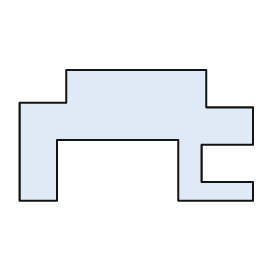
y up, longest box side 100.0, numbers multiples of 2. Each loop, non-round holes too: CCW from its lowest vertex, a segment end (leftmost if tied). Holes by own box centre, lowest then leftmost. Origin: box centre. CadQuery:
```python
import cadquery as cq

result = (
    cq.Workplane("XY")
    .moveTo(-50.0, -28.0)
    .lineTo(-34.0, -28.0)
    .lineTo(-34.0, -2.0)
    .lineTo(18.0, -2.0)
    .lineTo(18.0, -28.0)
    .lineTo(50.0, -28.0)
    .lineTo(50.0, -20.0)
    .lineTo(28.0, -20.0)
    .lineTo(28.0, -4.0)
    .lineTo(50.0, -4.0)
    .lineTo(50.0, 12.0)
    .lineTo(30.0, 12.0)
    .lineTo(30.0, 28.0)
    .lineTo(-30.0, 28.0)
    .lineTo(-30.0, 14.0)
    .lineTo(-50.0, 14.0)
    .close()
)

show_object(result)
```